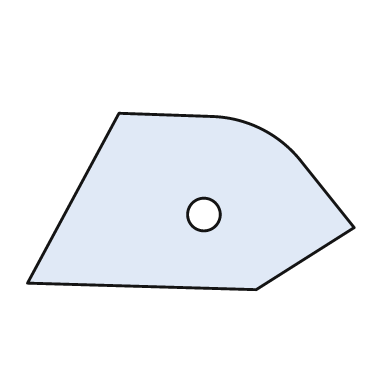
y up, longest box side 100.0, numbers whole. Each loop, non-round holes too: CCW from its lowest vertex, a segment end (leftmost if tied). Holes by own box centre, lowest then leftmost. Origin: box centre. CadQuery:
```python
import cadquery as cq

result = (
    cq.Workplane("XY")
    .moveTo(20.0, -27.0)
    .lineTo(50.0, -8.0)
    .lineTo(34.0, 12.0)
    .threePointArc((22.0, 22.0), (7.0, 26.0))
    .lineTo(-22.0, 27.0)
    .lineTo(-50.0, -25.0)
    .close()
    .moveTo(4.0, -4.0)
    .circle(5.0)
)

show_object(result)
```